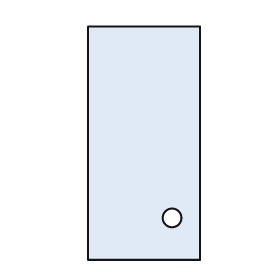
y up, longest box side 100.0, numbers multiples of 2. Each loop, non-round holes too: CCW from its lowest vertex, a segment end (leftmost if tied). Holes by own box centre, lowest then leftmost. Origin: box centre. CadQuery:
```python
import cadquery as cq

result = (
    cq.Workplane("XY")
    .moveTo(-24.0, -50.0)
    .lineTo(24.0, -50.0)
    .lineTo(24.0, 50.0)
    .lineTo(-24.0, 50.0)
    .close()
    .moveTo(12.0, -32.0)
    .circle(4.0)
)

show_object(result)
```